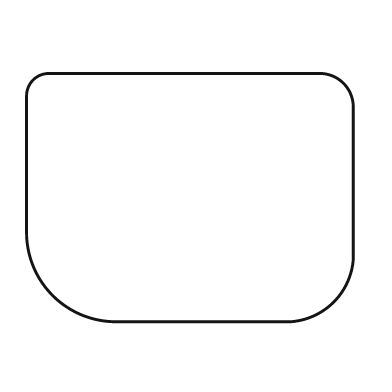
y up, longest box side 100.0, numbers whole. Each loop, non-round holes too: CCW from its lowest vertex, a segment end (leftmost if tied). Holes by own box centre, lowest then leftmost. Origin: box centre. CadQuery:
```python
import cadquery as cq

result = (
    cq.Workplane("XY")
    .moveTo(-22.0, -38.0)
    .lineTo(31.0, -38.0)
    .threePointArc((44.0, -32.0), (50.0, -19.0))
    .lineTo(50.0, 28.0)
    .threePointArc((47.0, 35.0), (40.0, 38.0))
    .lineTo(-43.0, 38.0)
    .threePointArc((-48.0, 36.0), (-50.0, 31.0))
    .lineTo(-50.0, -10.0)
    .threePointArc((-42.0, -30.0), (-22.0, -38.0))
    .close()
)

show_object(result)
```